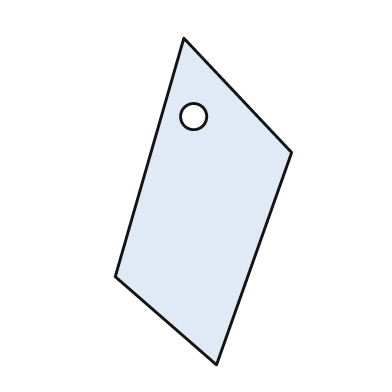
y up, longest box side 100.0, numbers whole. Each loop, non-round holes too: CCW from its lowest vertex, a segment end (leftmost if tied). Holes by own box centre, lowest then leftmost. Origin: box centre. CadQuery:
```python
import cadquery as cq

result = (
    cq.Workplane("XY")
    .moveTo(4.0, -50.0)
    .lineTo(27.0, 15.0)
    .lineTo(-6.0, 50.0)
    .lineTo(-27.0, -23.0)
    .close()
    .moveTo(-3.0, 26.0)
    .circle(4.0)
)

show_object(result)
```